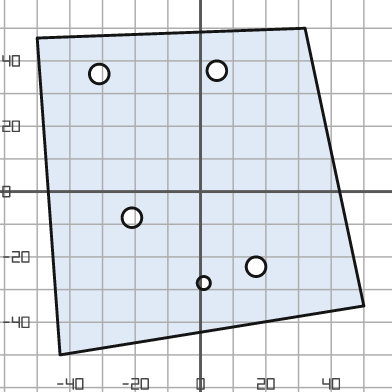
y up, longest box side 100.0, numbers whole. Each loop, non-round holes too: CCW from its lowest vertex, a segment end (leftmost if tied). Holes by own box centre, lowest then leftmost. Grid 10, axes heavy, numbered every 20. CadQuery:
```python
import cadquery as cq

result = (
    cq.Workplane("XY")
    .moveTo(-43.0, -50.0)
    .lineTo(50.0, -35.0)
    .lineTo(32.0, 50.0)
    .lineTo(-50.0, 47.0)
    .close()
    .moveTo(1.0, -28.0)
    .circle(2.0)
    .moveTo(17.0, -23.0)
    .circle(3.0)
    .moveTo(-21.0, -8.0)
    .circle(3.0)
    .moveTo(-31.0, 36.0)
    .circle(3.0)
    .moveTo(5.0, 37.0)
    .circle(3.0)
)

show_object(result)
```